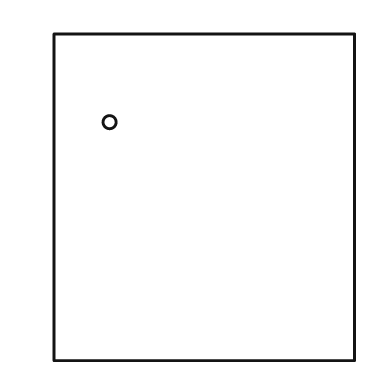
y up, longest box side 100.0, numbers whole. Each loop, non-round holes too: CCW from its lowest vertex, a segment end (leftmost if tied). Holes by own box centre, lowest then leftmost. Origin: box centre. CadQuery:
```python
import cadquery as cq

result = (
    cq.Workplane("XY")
    .moveTo(-46.0, -50.0)
    .lineTo(46.0, -50.0)
    .lineTo(46.0, 50.0)
    .lineTo(-46.0, 50.0)
    .close()
    .moveTo(-29.0, 23.0)
    .circle(2.0)
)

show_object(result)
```